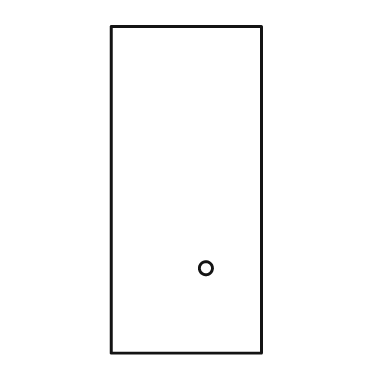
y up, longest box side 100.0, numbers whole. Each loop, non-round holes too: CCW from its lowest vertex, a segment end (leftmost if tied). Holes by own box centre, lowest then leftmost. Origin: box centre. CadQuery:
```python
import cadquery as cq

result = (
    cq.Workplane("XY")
    .moveTo(-23.0, -50.0)
    .lineTo(23.0, -50.0)
    .lineTo(23.0, 50.0)
    .lineTo(-23.0, 50.0)
    .close()
    .moveTo(6.0, -24.0)
    .circle(2.0)
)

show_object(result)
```